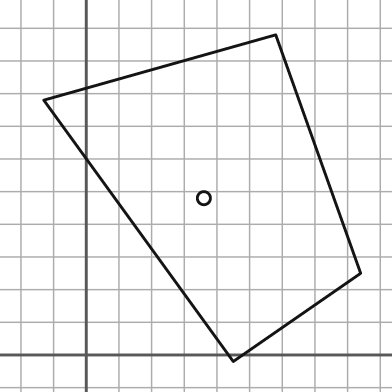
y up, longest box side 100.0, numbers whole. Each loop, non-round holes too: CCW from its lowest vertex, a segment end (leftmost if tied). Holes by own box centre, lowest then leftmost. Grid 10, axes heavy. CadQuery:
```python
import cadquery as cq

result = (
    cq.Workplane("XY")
    .moveTo(45.0, -2.0)
    .lineTo(84.0, 25.0)
    .lineTo(58.0, 98.0)
    .lineTo(-13.0, 78.0)
    .close()
    .moveTo(36.0, 48.0)
    .circle(2.0)
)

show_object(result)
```